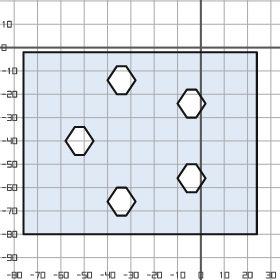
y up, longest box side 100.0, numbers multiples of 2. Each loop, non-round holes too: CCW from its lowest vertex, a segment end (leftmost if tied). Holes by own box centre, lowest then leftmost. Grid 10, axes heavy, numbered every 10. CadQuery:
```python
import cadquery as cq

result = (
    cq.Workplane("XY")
    .moveTo(-76.0, -80.0)
    .lineTo(24.0, -80.0)
    .lineTo(24.0, -2.0)
    .lineTo(-76.0, -2.0)
    .close()
    .moveTo(-36.0, -72.0)
    .lineTo(-32.0, -72.0)
    .lineTo(-28.0, -66.0)
    .lineTo(-32.0, -60.0)
    .lineTo(-36.0, -60.0)
    .lineTo(-40.0, -66.0)
    .close()
    .moveTo(-6.0, -62.0)
    .lineTo(-2.0, -62.0)
    .lineTo(2.0, -56.0)
    .lineTo(-2.0, -50.0)
    .lineTo(-6.0, -50.0)
    .lineTo(-10.0, -56.0)
    .close()
    .moveTo(-54.0, -46.0)
    .lineTo(-50.0, -46.0)
    .lineTo(-46.0, -40.0)
    .lineTo(-50.0, -34.0)
    .lineTo(-54.0, -34.0)
    .lineTo(-58.0, -40.0)
    .close()
    .moveTo(-6.0, -30.0)
    .lineTo(-2.0, -30.0)
    .lineTo(2.0, -24.0)
    .lineTo(-2.0, -18.0)
    .lineTo(-6.0, -18.0)
    .lineTo(-10.0, -24.0)
    .close()
    .moveTo(-36.0, -20.0)
    .lineTo(-32.0, -20.0)
    .lineTo(-28.0, -14.0)
    .lineTo(-32.0, -8.0)
    .lineTo(-36.0, -8.0)
    .lineTo(-40.0, -14.0)
    .close()
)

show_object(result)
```